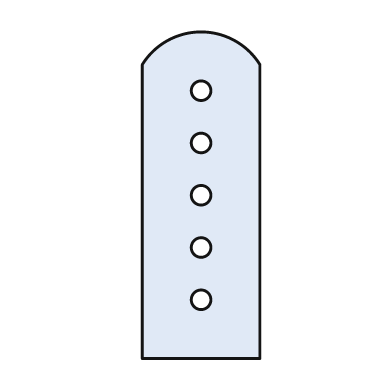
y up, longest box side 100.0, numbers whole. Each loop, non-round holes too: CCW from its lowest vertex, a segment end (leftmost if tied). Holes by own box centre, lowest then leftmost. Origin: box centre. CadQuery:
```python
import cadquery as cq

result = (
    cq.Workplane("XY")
    .moveTo(-18.0, -50.0)
    .lineTo(18.0, -50.0)
    .lineTo(18.0, 40.0)
    .threePointArc((0.0, 50.0), (-18.0, 40.0))
    .close()
    .moveTo(0.0, -32.0)
    .circle(3.0)
    .moveTo(0.0, -16.0)
    .circle(3.0)
    .moveTo(0.0, 0.0)
    .circle(3.0)
    .moveTo(0.0, 16.0)
    .circle(3.0)
    .moveTo(0.0, 32.0)
    .circle(3.0)
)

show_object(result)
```